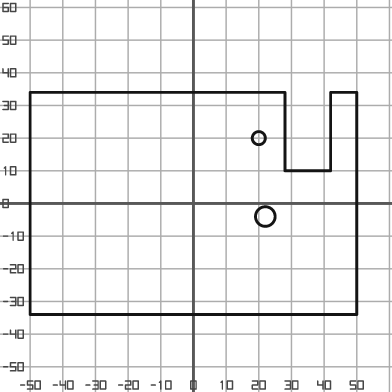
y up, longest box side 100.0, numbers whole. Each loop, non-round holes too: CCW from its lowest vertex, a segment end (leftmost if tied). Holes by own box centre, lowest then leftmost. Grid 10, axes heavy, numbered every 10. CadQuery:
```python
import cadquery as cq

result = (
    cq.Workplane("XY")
    .moveTo(-50.0, -34.0)
    .lineTo(50.0, -34.0)
    .lineTo(50.0, 34.0)
    .lineTo(42.0, 34.0)
    .lineTo(42.0, 10.0)
    .lineTo(28.0, 10.0)
    .lineTo(28.0, 34.0)
    .lineTo(-50.0, 34.0)
    .close()
    .moveTo(22.0, -4.0)
    .circle(3.0)
    .moveTo(20.0, 20.0)
    .circle(2.0)
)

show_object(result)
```